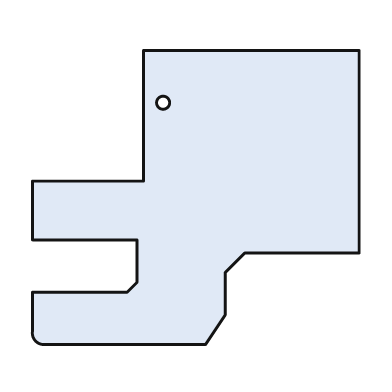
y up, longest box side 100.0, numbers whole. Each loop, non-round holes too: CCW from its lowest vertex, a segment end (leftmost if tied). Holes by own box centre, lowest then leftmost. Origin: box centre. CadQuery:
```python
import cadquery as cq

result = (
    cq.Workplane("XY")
    .moveTo(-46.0, -45.0)
    .lineTo(3.0, -45.0)
    .lineTo(9.0, -36.0)
    .lineTo(9.0, -23.0)
    .lineTo(15.0, -17.0)
    .lineTo(50.0, -17.0)
    .lineTo(50.0, 45.0)
    .lineTo(-16.0, 45.0)
    .lineTo(-16.0, 5.0)
    .lineTo(-50.0, 5.0)
    .lineTo(-50.0, -13.0)
    .lineTo(-18.0, -13.0)
    .lineTo(-18.0, -26.0)
    .lineTo(-21.0, -29.0)
    .lineTo(-50.0, -29.0)
    .lineTo(-50.0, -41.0)
    .threePointArc((-49.0, -44.0), (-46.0, -45.0))
    .close()
    .moveTo(-10.0, 29.0)
    .circle(2.0)
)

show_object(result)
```